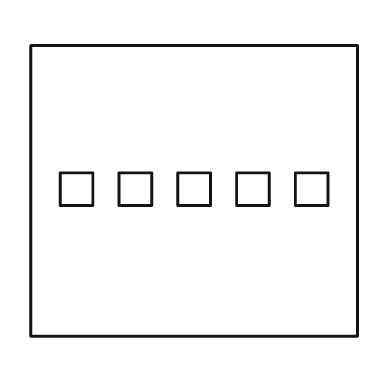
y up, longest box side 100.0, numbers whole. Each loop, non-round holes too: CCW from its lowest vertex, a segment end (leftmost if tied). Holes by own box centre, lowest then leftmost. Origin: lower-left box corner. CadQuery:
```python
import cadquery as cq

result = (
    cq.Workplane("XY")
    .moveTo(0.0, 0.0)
    .lineTo(100.0, 0.0)
    .lineTo(100.0, 89.0)
    .lineTo(0.0, 89.0)
    .close()
    .moveTo(9.0, 40.0)
    .lineTo(19.0, 40.0)
    .lineTo(19.0, 50.0)
    .lineTo(9.0, 50.0)
    .close()
    .moveTo(27.0, 40.0)
    .lineTo(37.0, 40.0)
    .lineTo(37.0, 50.0)
    .lineTo(27.0, 50.0)
    .close()
    .moveTo(45.0, 40.0)
    .lineTo(55.0, 40.0)
    .lineTo(55.0, 50.0)
    .lineTo(45.0, 50.0)
    .close()
    .moveTo(63.0, 40.0)
    .lineTo(73.0, 40.0)
    .lineTo(73.0, 50.0)
    .lineTo(63.0, 50.0)
    .close()
    .moveTo(81.0, 40.0)
    .lineTo(91.0, 40.0)
    .lineTo(91.0, 50.0)
    .lineTo(81.0, 50.0)
    .close()
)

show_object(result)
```